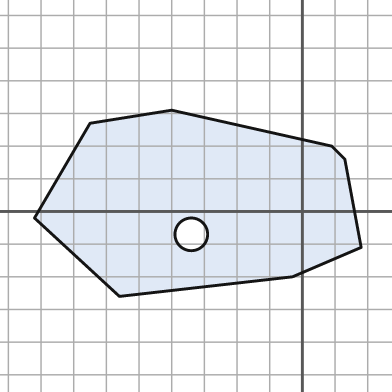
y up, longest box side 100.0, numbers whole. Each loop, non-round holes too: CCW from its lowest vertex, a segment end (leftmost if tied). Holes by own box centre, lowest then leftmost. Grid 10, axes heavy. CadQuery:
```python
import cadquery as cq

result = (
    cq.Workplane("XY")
    .moveTo(-56.0, -26.0)
    .lineTo(-3.0, -20.0)
    .lineTo(18.0, -11.0)
    .lineTo(13.0, 16.0)
    .lineTo(9.0, 20.0)
    .lineTo(-40.0, 31.0)
    .lineTo(-65.0, 27.0)
    .lineTo(-82.0, -2.0)
    .close()
    .moveTo(-34.0, -7.0)
    .circle(5.0)
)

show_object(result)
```